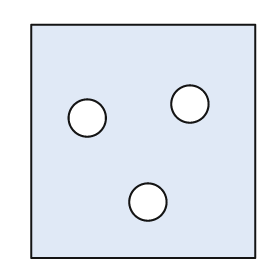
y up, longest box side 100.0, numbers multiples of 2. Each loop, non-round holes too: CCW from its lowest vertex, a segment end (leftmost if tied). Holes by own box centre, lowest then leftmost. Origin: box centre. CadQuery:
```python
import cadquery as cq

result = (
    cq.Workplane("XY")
    .moveTo(-48.0, -50.0)
    .lineTo(48.0, -50.0)
    .lineTo(48.0, 50.0)
    .lineTo(-48.0, 50.0)
    .close()
    .moveTo(2.0, -26.0)
    .circle(8.0)
    .moveTo(-24.0, 10.0)
    .circle(8.0)
    .moveTo(20.0, 16.0)
    .circle(8.0)
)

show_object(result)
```